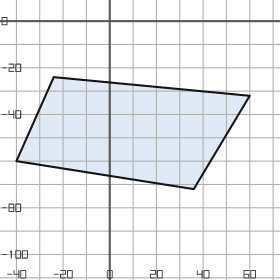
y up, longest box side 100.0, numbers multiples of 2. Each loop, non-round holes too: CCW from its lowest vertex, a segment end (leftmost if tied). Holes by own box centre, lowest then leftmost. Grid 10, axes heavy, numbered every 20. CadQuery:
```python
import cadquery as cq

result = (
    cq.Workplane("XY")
    .moveTo(36.0, -72.0)
    .lineTo(60.0, -32.0)
    .lineTo(-24.0, -24.0)
    .lineTo(-40.0, -60.0)
    .close()
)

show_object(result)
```